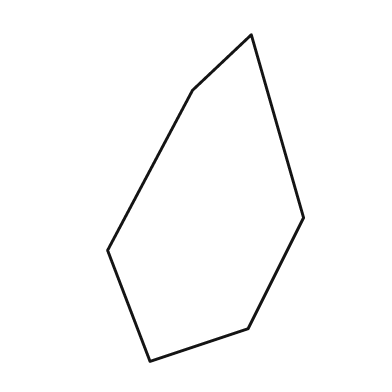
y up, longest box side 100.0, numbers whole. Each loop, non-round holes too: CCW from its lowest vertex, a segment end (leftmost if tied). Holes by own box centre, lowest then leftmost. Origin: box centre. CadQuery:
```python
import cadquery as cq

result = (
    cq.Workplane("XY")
    .moveTo(-17.0, -50.0)
    .lineTo(13.0, -40.0)
    .lineTo(30.0, -6.0)
    .lineTo(14.0, 50.0)
    .lineTo(-4.0, 33.0)
    .lineTo(-30.0, -16.0)
    .close()
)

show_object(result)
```